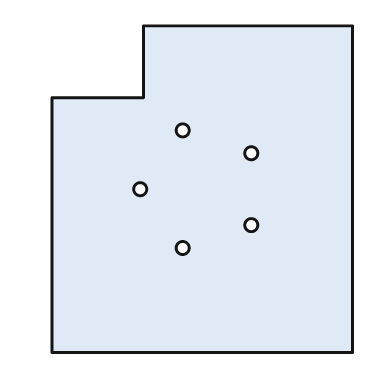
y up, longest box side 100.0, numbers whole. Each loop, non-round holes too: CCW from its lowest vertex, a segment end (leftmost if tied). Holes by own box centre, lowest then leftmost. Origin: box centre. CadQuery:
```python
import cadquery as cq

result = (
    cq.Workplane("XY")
    .moveTo(-46.0, -50.0)
    .lineTo(46.0, -50.0)
    .lineTo(46.0, 50.0)
    .lineTo(-18.0, 50.0)
    .lineTo(-18.0, 28.0)
    .lineTo(-46.0, 28.0)
    .close()
    .moveTo(-6.0, -18.0)
    .circle(2.0)
    .moveTo(15.0, -11.0)
    .circle(2.0)
    .moveTo(-19.0, 0.0)
    .circle(2.0)
    .moveTo(15.0, 11.0)
    .circle(2.0)
    .moveTo(-6.0, 18.0)
    .circle(2.0)
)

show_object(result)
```